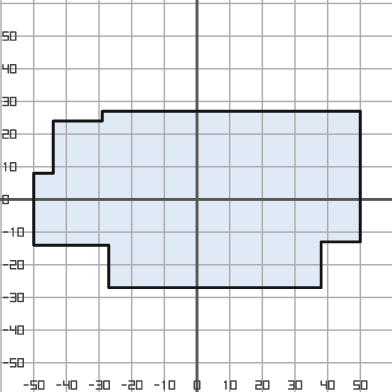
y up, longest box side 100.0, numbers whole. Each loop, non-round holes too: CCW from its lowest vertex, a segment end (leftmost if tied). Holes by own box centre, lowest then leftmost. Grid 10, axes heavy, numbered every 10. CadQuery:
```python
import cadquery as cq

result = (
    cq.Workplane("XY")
    .moveTo(-27.0, -27.0)
    .lineTo(38.0, -27.0)
    .lineTo(38.0, -13.0)
    .lineTo(50.0, -13.0)
    .lineTo(50.0, 27.0)
    .lineTo(-29.0, 27.0)
    .lineTo(-29.0, 24.0)
    .lineTo(-44.0, 24.0)
    .lineTo(-44.0, 8.0)
    .lineTo(-50.0, 8.0)
    .lineTo(-50.0, -14.0)
    .lineTo(-27.0, -14.0)
    .close()
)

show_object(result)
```